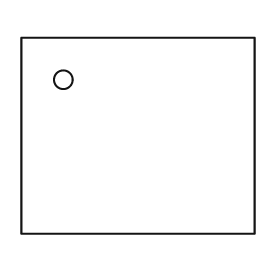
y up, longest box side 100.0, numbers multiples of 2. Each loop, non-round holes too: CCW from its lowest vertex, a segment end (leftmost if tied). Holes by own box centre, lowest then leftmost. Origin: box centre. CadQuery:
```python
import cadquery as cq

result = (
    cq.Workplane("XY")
    .moveTo(-50.0, -42.0)
    .lineTo(50.0, -42.0)
    .lineTo(50.0, 42.0)
    .lineTo(-50.0, 42.0)
    .close()
    .moveTo(-32.0, 24.0)
    .circle(4.0)
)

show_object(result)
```